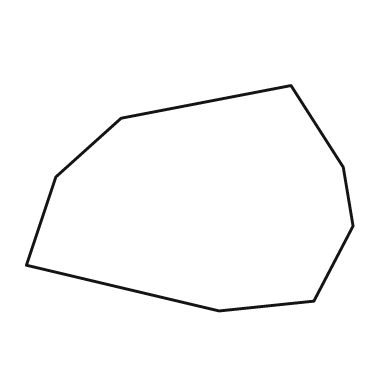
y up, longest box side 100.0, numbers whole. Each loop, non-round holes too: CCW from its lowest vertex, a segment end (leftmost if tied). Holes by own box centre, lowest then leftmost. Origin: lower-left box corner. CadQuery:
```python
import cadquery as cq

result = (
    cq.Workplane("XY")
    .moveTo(59.0, 0.0)
    .lineTo(88.0, 3.0)
    .lineTo(100.0, 26.0)
    .lineTo(97.0, 44.0)
    .lineTo(81.0, 69.0)
    .lineTo(29.0, 59.0)
    .lineTo(9.0, 41.0)
    .lineTo(0.0, 14.0)
    .close()
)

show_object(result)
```